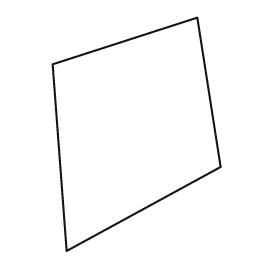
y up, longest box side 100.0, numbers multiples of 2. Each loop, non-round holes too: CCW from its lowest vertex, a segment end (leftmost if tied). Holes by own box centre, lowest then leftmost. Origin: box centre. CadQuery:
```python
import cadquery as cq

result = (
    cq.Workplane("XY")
    .moveTo(-30.0, -50.0)
    .lineTo(36.0, -14.0)
    .lineTo(26.0, 50.0)
    .lineTo(-36.0, 30.0)
    .close()
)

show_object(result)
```